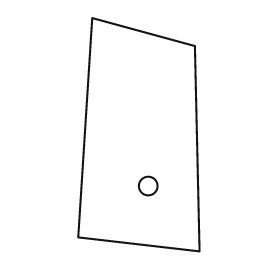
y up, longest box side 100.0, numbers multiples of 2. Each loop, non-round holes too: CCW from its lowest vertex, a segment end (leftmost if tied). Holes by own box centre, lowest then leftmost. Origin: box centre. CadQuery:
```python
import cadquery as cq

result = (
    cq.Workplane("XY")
    .moveTo(26.0, -50.0)
    .lineTo(24.0, 38.0)
    .lineTo(-20.0, 50.0)
    .lineTo(-26.0, -44.0)
    .close()
    .moveTo(4.0, -22.0)
    .circle(4.0)
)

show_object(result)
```